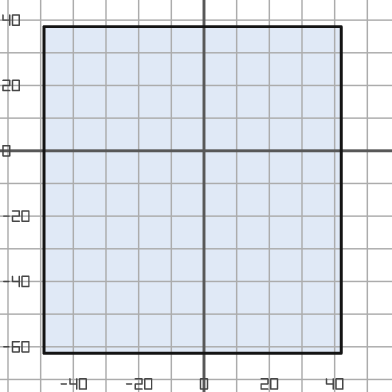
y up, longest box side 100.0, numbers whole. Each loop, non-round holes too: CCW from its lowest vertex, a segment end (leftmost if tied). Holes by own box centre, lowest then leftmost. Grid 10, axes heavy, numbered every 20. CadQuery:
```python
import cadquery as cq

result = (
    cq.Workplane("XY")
    .moveTo(-49.0, -62.0)
    .lineTo(42.0, -62.0)
    .lineTo(42.0, 38.0)
    .lineTo(-49.0, 38.0)
    .close()
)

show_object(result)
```